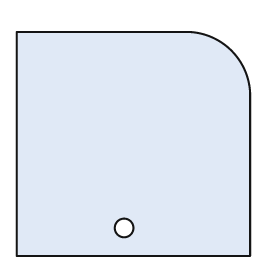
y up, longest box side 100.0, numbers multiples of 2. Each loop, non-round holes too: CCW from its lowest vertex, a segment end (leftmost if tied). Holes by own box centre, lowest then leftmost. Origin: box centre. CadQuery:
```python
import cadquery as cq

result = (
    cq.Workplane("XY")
    .moveTo(-50.0, -48.0)
    .lineTo(50.0, -48.0)
    .lineTo(50.0, 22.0)
    .threePointArc((42.0, 40.0), (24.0, 48.0))
    .lineTo(-50.0, 48.0)
    .close()
    .moveTo(-4.0, -36.0)
    .circle(4.0)
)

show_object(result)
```